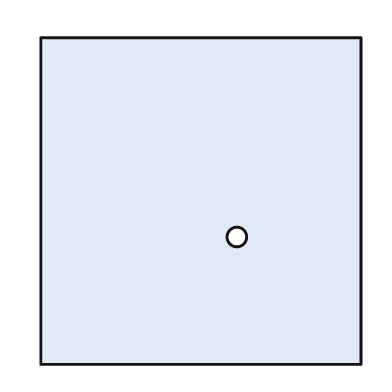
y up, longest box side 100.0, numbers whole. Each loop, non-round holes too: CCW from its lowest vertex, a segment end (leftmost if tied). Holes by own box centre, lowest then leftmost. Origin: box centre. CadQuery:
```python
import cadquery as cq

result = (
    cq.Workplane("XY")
    .moveTo(-49.0, -50.0)
    .lineTo(49.0, -50.0)
    .lineTo(49.0, 50.0)
    .lineTo(-49.0, 50.0)
    .close()
    .moveTo(11.0, -11.0)
    .circle(3.0)
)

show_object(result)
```